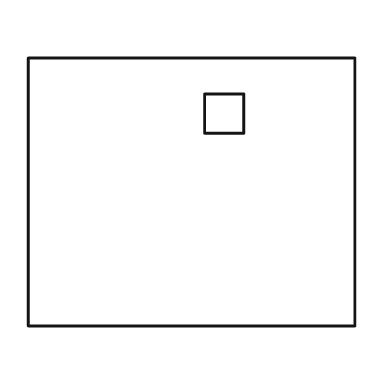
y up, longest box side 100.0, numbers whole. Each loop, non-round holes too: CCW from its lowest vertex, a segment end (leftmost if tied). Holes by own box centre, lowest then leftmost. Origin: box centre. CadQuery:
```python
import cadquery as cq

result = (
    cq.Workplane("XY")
    .moveTo(-50.0, -41.0)
    .lineTo(50.0, -41.0)
    .lineTo(50.0, 41.0)
    .lineTo(-50.0, 41.0)
    .close()
    .moveTo(4.0, 18.0)
    .lineTo(16.0, 18.0)
    .lineTo(16.0, 30.0)
    .lineTo(4.0, 30.0)
    .close()
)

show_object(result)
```